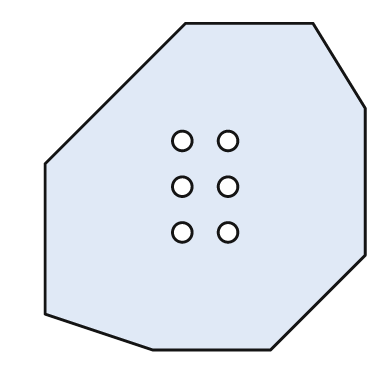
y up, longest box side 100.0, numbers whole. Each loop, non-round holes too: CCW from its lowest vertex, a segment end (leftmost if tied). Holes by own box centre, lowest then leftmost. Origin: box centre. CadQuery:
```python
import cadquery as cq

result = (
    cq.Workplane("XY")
    .moveTo(-16.0, -50.0)
    .lineTo(20.0, -50.0)
    .lineTo(49.0, -21.0)
    .lineTo(49.0, 24.0)
    .lineTo(33.0, 50.0)
    .lineTo(-6.0, 50.0)
    .lineTo(-49.0, 7.0)
    .lineTo(-49.0, -39.0)
    .close()
    .moveTo(-7.0, -14.0)
    .circle(3.0)
    .moveTo(7.0, -14.0)
    .circle(3.0)
    .moveTo(-7.0, 0.0)
    .circle(3.0)
    .moveTo(7.0, 0.0)
    .circle(3.0)
    .moveTo(-7.0, 14.0)
    .circle(3.0)
    .moveTo(7.0, 14.0)
    .circle(3.0)
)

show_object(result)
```